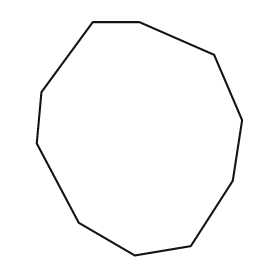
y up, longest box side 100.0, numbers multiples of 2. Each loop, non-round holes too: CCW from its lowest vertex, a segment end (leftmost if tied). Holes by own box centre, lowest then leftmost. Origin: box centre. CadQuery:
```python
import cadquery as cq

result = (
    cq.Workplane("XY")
    .moveTo(-2.0, -50.0)
    .lineTo(22.0, -46.0)
    .lineTo(40.0, -18.0)
    .lineTo(44.0, 8.0)
    .lineTo(32.0, 36.0)
    .lineTo(0.0, 50.0)
    .lineTo(-20.0, 50.0)
    .lineTo(-42.0, 20.0)
    .lineTo(-44.0, -2.0)
    .lineTo(-26.0, -36.0)
    .close()
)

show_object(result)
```